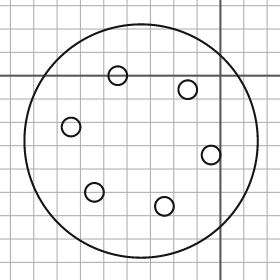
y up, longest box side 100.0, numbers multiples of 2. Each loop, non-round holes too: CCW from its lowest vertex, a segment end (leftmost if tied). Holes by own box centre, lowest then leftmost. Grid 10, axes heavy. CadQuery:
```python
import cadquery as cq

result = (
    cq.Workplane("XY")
    .moveTo(-34.0, -28.0)
    .circle(50.0)
    .moveTo(-24.0, -56.0)
    .circle(4.0)
    .moveTo(-54.0, -50.0)
    .circle(4.0)
    .moveTo(-4.0, -34.0)
    .circle(4.0)
    .moveTo(-64.0, -22.0)
    .circle(4.0)
    .moveTo(-14.0, -6.0)
    .circle(4.0)
    .moveTo(-44.0, 0.0)
    .circle(4.0)
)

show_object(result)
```